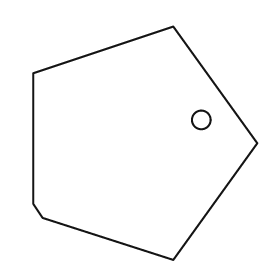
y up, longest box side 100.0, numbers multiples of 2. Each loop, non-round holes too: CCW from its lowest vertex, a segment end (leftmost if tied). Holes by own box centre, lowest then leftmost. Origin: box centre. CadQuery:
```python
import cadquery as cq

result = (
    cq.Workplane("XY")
    .moveTo(12.0, -50.0)
    .lineTo(48.0, 0.0)
    .lineTo(12.0, 50.0)
    .lineTo(-48.0, 30.0)
    .lineTo(-48.0, -26.0)
    .lineTo(-44.0, -32.0)
    .close()
    .moveTo(24.0, 10.0)
    .circle(4.0)
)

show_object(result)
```